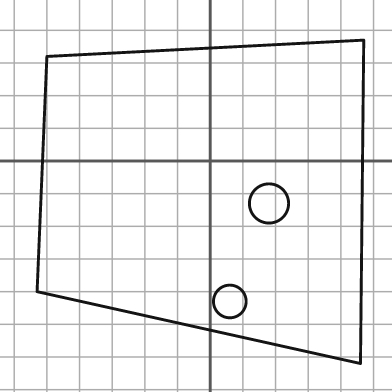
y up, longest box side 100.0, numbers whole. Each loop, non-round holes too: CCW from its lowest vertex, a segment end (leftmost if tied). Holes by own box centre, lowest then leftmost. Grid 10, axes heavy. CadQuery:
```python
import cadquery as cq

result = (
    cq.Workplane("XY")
    .moveTo(46.0, -62.0)
    .lineTo(47.0, 37.0)
    .lineTo(-50.0, 32.0)
    .lineTo(-53.0, -40.0)
    .close()
    .moveTo(6.0, -43.0)
    .circle(5.0)
    .moveTo(18.0, -13.0)
    .circle(6.0)
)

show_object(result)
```